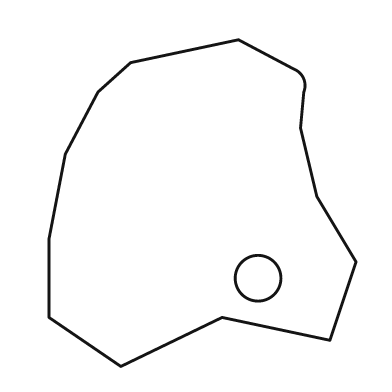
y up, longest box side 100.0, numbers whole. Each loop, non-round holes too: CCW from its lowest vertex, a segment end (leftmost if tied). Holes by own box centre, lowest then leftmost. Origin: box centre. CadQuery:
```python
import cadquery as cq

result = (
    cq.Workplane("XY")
    .moveTo(-25.0, -50.0)
    .lineTo(6.0, -35.0)
    .lineTo(39.0, -42.0)
    .lineTo(47.0, -18.0)
    .lineTo(35.0, 2.0)
    .lineTo(30.0, 23.0)
    .lineTo(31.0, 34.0)
    .threePointArc((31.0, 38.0), (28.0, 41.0))
    .lineTo(11.0, 50.0)
    .lineTo(-22.0, 43.0)
    .lineTo(-32.0, 34.0)
    .lineTo(-42.0, 15.0)
    .lineTo(-47.0, -11.0)
    .lineTo(-47.0, -35.0)
    .close()
    .moveTo(17.0, -23.0)
    .circle(7.0)
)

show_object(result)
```